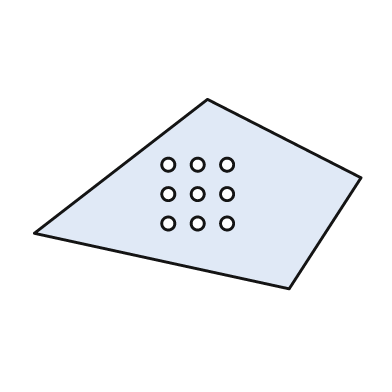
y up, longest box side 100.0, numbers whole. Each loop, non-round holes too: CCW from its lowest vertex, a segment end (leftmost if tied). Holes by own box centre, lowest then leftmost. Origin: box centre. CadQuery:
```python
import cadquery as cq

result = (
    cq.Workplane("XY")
    .moveTo(28.0, -29.0)
    .lineTo(50.0, 5.0)
    .lineTo(3.0, 29.0)
    .lineTo(-50.0, -12.0)
    .close()
    .moveTo(-9.0, -9.0)
    .circle(2.0)
    .moveTo(0.0, -9.0)
    .circle(2.0)
    .moveTo(9.0, -9.0)
    .circle(2.0)
    .moveTo(-9.0, 0.0)
    .circle(2.0)
    .moveTo(0.0, 0.0)
    .circle(2.0)
    .moveTo(9.0, 0.0)
    .circle(2.0)
    .moveTo(-9.0, 9.0)
    .circle(2.0)
    .moveTo(0.0, 9.0)
    .circle(2.0)
    .moveTo(9.0, 9.0)
    .circle(2.0)
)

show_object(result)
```